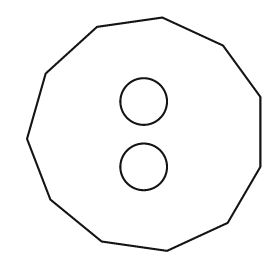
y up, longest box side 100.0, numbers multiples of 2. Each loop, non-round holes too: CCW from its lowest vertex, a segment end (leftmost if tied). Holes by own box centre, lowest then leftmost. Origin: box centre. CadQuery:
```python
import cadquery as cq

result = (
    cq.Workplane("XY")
    .moveTo(10.0, -50.0)
    .lineTo(36.0, -38.0)
    .lineTo(50.0, -14.0)
    .lineTo(50.0, 16.0)
    .lineTo(34.0, 38.0)
    .lineTo(8.0, 50.0)
    .lineTo(-20.0, 46.0)
    .lineTo(-42.0, 26.0)
    .lineTo(-50.0, -2.0)
    .lineTo(-40.0, -28.0)
    .lineTo(-18.0, -46.0)
    .close()
    .moveTo(0.0, -14.0)
    .circle(10.0)
    .moveTo(0.0, 14.0)
    .circle(10.0)
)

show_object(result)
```